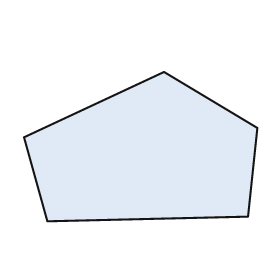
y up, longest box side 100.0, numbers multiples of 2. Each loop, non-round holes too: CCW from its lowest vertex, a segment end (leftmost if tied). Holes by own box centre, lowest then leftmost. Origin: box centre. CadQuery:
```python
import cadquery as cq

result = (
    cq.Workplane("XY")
    .moveTo(-40.0, -32.0)
    .lineTo(46.0, -30.0)
    .lineTo(50.0, 8.0)
    .lineTo(10.0, 32.0)
    .lineTo(-50.0, 4.0)
    .close()
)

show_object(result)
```